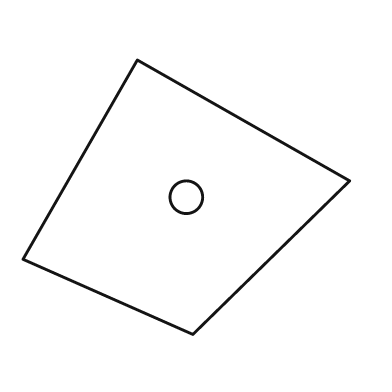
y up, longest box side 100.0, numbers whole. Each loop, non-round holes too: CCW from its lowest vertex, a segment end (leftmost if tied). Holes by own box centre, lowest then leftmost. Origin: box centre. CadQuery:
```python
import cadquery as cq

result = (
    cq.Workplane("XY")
    .moveTo(2.0, -42.0)
    .lineTo(50.0, 5.0)
    .lineTo(-15.0, 42.0)
    .lineTo(-50.0, -19.0)
    .close()
    .moveTo(0.0, 0.0)
    .circle(5.0)
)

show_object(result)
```